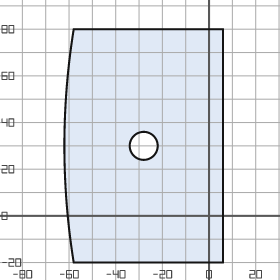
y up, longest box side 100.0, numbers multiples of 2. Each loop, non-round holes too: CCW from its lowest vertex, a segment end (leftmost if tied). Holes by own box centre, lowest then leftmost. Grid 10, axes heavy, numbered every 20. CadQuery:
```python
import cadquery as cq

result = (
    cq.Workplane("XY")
    .moveTo(-58.0, -20.0)
    .lineTo(6.0, -20.0)
    .lineTo(6.0, 80.0)
    .lineTo(-58.0, 80.0)
    .threePointArc((-62.0, 30.0), (-58.0, -20.0))
    .close()
    .moveTo(-28.0, 30.0)
    .circle(6.0)
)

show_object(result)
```